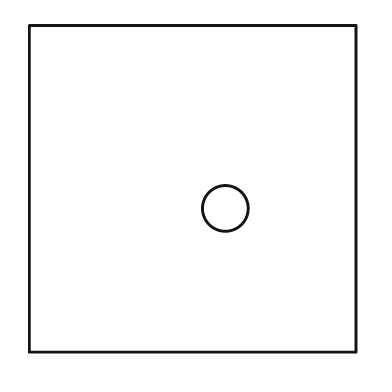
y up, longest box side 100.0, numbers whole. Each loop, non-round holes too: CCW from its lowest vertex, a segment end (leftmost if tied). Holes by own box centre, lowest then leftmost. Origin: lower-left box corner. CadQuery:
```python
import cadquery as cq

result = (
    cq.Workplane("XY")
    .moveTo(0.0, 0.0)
    .lineTo(100.0, 0.0)
    .lineTo(100.0, 100.0)
    .lineTo(0.0, 100.0)
    .close()
    .moveTo(60.0, 44.0)
    .circle(7.0)
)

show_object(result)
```